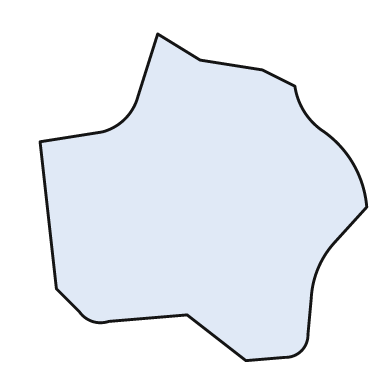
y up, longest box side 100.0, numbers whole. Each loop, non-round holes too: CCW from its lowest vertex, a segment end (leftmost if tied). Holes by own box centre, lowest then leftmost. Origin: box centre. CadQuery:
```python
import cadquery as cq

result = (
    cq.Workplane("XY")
    .moveTo(13.0, -50.0)
    .lineTo(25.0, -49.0)
    .threePointArc((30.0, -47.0), (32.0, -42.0))
    .lineTo(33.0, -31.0)
    .threePointArc((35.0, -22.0), (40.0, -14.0))
    .lineTo(50.0, -3.0)
    .threePointArc((46.0, 10.0), (37.0, 20.0))
    .threePointArc((31.0, 26.0), (28.0, 34.0))
    .lineTo(18.0, 39.0)
    .lineTo(-1.0, 42.0)
    .lineTo(-14.0, 50.0)
    .lineTo(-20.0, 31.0)
    .threePointArc((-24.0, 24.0), (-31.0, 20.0))
    .lineTo(-50.0, 17.0)
    .lineTo(-45.0, -28.0)
    .lineTo(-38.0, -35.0)
    .threePointArc((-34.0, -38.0), (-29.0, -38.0))
    .lineTo(-5.0, -36.0)
    .close()
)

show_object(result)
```